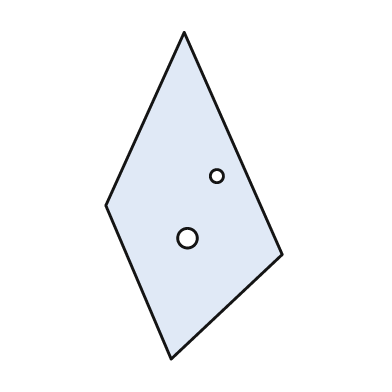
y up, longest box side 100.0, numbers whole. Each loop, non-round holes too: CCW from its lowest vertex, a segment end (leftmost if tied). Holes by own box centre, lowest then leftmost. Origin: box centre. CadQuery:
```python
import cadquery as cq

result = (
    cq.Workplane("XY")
    .moveTo(-7.0, -50.0)
    .lineTo(27.0, -18.0)
    .lineTo(-3.0, 50.0)
    .lineTo(-27.0, -3.0)
    .close()
    .moveTo(-2.0, -13.0)
    .circle(3.0)
    .moveTo(7.0, 6.0)
    .circle(2.0)
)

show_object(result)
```